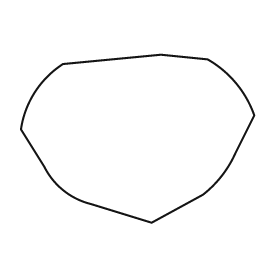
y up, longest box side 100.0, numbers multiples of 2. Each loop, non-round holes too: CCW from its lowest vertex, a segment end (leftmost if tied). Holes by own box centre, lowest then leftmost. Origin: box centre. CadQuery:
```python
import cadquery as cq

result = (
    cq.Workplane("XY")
    .moveTo(6.0, -36.0)
    .lineTo(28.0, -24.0)
    .threePointArc((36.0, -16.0), (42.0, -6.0))
    .lineTo(50.0, 10.0)
    .threePointArc((42.0, 24.0), (30.0, 34.0))
    .lineTo(10.0, 36.0)
    .lineTo(-32.0, 32.0)
    .threePointArc((-44.0, 20.0), (-50.0, 4.0))
    .lineTo(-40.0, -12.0)
    .threePointArc((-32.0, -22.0), (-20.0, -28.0))
    .close()
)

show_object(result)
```